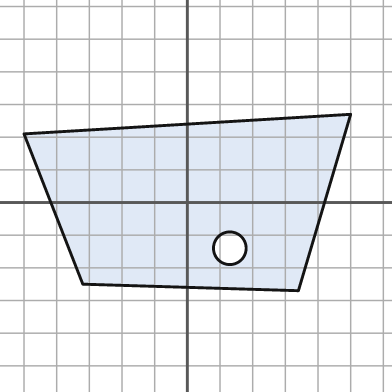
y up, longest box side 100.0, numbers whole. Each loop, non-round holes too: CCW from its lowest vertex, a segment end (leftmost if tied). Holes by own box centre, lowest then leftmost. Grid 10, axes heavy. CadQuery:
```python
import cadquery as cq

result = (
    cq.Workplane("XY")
    .moveTo(34.0, -27.0)
    .lineTo(50.0, 27.0)
    .lineTo(-50.0, 21.0)
    .lineTo(-32.0, -25.0)
    .close()
    .moveTo(13.0, -14.0)
    .circle(5.0)
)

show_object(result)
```